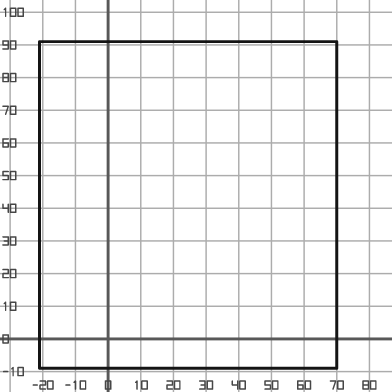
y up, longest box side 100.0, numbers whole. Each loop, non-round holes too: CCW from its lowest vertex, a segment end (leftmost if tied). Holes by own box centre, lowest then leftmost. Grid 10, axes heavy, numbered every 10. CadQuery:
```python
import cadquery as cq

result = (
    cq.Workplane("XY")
    .moveTo(-21.0, -9.0)
    .lineTo(70.0, -9.0)
    .lineTo(70.0, 91.0)
    .lineTo(-21.0, 91.0)
    .close()
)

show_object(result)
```